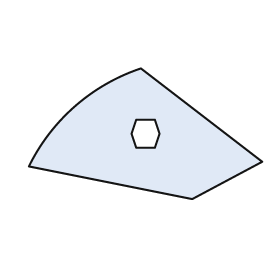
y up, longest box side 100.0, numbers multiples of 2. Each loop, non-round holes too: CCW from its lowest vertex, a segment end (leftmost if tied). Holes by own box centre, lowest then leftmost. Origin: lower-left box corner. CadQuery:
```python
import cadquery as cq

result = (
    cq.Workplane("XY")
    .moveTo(70.0, 0.0)
    .lineTo(100.0, 16.0)
    .lineTo(48.0, 56.0)
    .threePointArc((20.0, 40.0), (0.0, 14.0))
    .close()
    .moveTo(46.0, 22.0)
    .lineTo(54.0, 22.0)
    .lineTo(56.0, 28.0)
    .lineTo(54.0, 34.0)
    .lineTo(46.0, 34.0)
    .lineTo(44.0, 28.0)
    .close()
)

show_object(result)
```